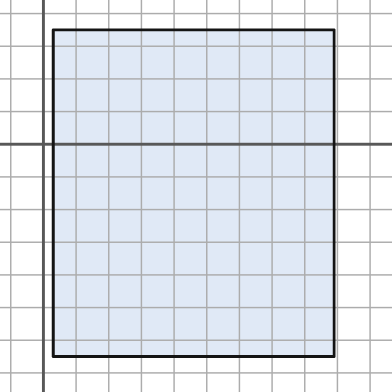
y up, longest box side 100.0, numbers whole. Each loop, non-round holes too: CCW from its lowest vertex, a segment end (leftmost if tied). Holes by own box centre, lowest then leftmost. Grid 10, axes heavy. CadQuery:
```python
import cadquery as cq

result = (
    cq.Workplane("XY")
    .moveTo(3.0, -65.0)
    .lineTo(89.0, -65.0)
    .lineTo(89.0, 35.0)
    .lineTo(3.0, 35.0)
    .close()
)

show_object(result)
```